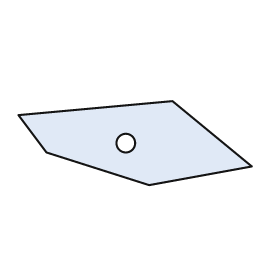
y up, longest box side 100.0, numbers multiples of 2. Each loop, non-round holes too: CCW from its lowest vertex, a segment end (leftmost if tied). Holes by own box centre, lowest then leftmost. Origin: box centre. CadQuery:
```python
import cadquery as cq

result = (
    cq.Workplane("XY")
    .moveTo(6.0, -18.0)
    .lineTo(50.0, -10.0)
    .lineTo(16.0, 18.0)
    .lineTo(-50.0, 12.0)
    .lineTo(-38.0, -4.0)
    .close()
    .moveTo(-4.0, 0.0)
    .circle(4.0)
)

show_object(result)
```